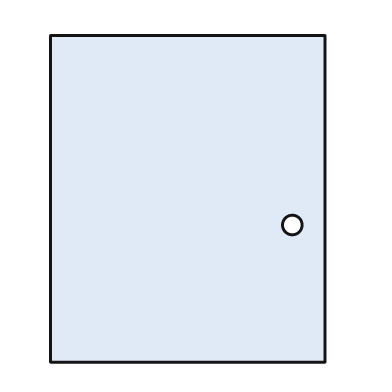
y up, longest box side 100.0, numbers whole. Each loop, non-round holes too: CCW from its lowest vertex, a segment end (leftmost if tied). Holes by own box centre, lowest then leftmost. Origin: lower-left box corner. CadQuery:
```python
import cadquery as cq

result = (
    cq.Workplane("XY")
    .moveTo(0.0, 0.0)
    .lineTo(84.0, 0.0)
    .lineTo(84.0, 100.0)
    .lineTo(0.0, 100.0)
    .close()
    .moveTo(74.0, 42.0)
    .circle(3.0)
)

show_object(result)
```